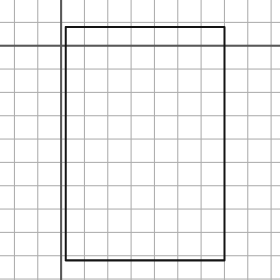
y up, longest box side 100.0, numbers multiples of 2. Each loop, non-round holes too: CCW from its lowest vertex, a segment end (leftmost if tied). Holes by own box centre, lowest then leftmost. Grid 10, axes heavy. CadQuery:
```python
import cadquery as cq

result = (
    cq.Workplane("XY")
    .moveTo(2.0, -92.0)
    .lineTo(70.0, -92.0)
    .lineTo(70.0, 8.0)
    .lineTo(2.0, 8.0)
    .close()
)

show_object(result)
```